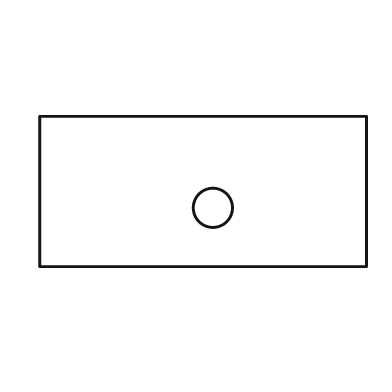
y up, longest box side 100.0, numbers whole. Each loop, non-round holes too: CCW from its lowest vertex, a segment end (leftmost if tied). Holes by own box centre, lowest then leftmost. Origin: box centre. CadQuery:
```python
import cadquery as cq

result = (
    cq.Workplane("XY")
    .moveTo(-50.0, -23.0)
    .lineTo(50.0, -23.0)
    .lineTo(50.0, 23.0)
    .lineTo(-50.0, 23.0)
    .close()
    .moveTo(3.0, -5.0)
    .circle(6.0)
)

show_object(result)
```